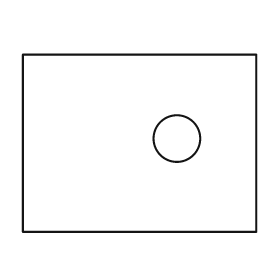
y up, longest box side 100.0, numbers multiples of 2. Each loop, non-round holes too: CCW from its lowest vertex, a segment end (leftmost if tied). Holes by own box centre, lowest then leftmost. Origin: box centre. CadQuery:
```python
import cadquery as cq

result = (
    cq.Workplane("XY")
    .moveTo(-50.0, -38.0)
    .lineTo(50.0, -38.0)
    .lineTo(50.0, 38.0)
    .lineTo(-50.0, 38.0)
    .close()
    .moveTo(16.0, 2.0)
    .circle(10.0)
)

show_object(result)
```